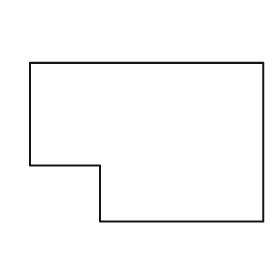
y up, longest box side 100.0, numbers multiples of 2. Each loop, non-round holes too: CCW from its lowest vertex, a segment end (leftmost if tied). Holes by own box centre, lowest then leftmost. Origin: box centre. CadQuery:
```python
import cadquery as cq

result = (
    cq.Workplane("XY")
    .moveTo(-20.0, -34.0)
    .lineTo(50.0, -34.0)
    .lineTo(50.0, 34.0)
    .lineTo(-50.0, 34.0)
    .lineTo(-50.0, -10.0)
    .lineTo(-20.0, -10.0)
    .close()
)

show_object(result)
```